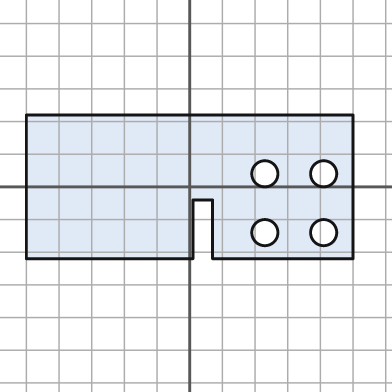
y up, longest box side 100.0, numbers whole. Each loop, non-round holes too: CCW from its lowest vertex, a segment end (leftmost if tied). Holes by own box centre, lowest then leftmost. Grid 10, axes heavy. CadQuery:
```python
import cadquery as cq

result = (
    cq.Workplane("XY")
    .moveTo(-50.0, -22.0)
    .lineTo(1.0, -22.0)
    .lineTo(1.0, -4.0)
    .lineTo(7.0, -4.0)
    .lineTo(7.0, -22.0)
    .lineTo(50.0, -22.0)
    .lineTo(50.0, 22.0)
    .lineTo(-50.0, 22.0)
    .close()
    .moveTo(23.0, -14.0)
    .circle(4.0)
    .moveTo(41.0, -14.0)
    .circle(4.0)
    .moveTo(23.0, 4.0)
    .circle(4.0)
    .moveTo(41.0, 4.0)
    .circle(4.0)
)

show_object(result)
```